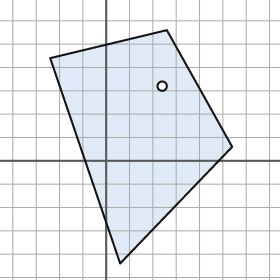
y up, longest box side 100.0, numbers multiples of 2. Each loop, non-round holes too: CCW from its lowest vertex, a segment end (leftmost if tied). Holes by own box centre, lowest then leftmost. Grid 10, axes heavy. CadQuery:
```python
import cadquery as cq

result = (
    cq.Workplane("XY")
    .moveTo(6.0, -44.0)
    .lineTo(54.0, 6.0)
    .lineTo(26.0, 56.0)
    .lineTo(-24.0, 44.0)
    .close()
    .moveTo(24.0, 32.0)
    .circle(2.0)
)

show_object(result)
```